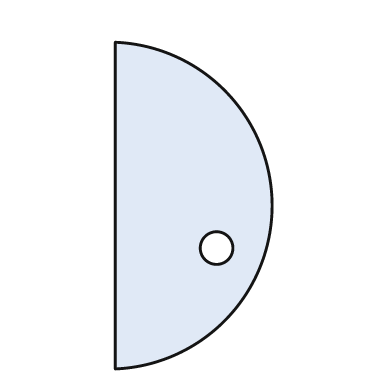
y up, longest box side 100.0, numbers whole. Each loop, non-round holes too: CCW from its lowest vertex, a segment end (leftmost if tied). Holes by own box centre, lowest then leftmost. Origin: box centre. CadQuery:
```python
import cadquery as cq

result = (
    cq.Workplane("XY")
    .moveTo(-24.0, -50.0)
    .threePointArc((24.0, 0.0), (-24.0, 50.0))
    .close()
    .moveTo(7.0, -13.0)
    .circle(5.0)
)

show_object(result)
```